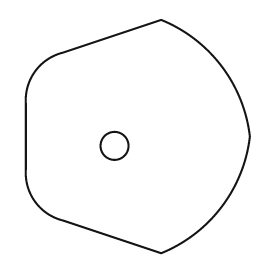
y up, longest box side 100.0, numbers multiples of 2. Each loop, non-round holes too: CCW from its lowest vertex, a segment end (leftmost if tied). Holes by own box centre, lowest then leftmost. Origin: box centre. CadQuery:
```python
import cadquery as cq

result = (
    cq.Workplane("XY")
    .moveTo(10.0, -50.0)
    .threePointArc((36.0, -30.0), (48.0, 0.0))
    .threePointArc((36.0, 30.0), (10.0, 50.0))
    .lineTo(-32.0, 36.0)
    .threePointArc((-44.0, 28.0), (-48.0, 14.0))
    .lineTo(-48.0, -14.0)
    .threePointArc((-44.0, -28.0), (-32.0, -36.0))
    .close()
    .moveTo(-10.0, -4.0)
    .circle(6.0)
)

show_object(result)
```